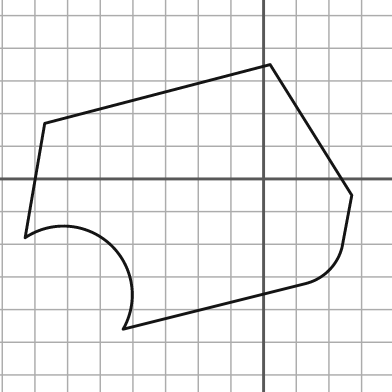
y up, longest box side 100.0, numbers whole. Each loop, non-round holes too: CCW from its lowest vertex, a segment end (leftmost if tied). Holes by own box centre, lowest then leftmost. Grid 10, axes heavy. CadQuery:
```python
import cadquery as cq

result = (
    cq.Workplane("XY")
    .moveTo(-43.0, -46.0)
    .lineTo(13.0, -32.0)
    .threePointArc((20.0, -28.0), (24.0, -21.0))
    .lineTo(27.0, -5.0)
    .lineTo(2.0, 35.0)
    .lineTo(-67.0, 17.0)
    .lineTo(-73.0, -18.0)
    .threePointArc((-47.0, -20.0), (-43.0, -46.0))
    .close()
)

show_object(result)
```